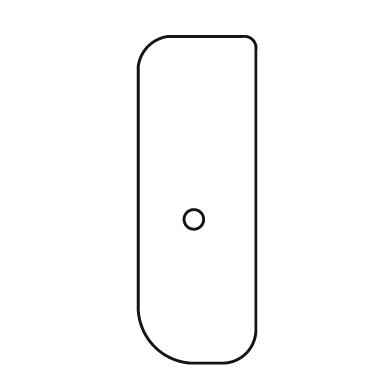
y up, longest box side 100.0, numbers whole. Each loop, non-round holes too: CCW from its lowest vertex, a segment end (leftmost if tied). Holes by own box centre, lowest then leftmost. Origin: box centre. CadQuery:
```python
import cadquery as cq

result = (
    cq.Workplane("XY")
    .moveTo(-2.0, -50.0)
    .lineTo(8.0, -50.0)
    .threePointArc((15.0, -47.0), (18.0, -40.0))
    .lineTo(18.0, 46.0)
    .threePointArc((17.0, 49.0), (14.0, 50.0))
    .lineTo(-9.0, 50.0)
    .threePointArc((-15.0, 47.0), (-18.0, 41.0))
    .lineTo(-18.0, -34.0)
    .threePointArc((-13.0, -45.0), (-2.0, -50.0))
    .close()
    .moveTo(-1.0, -6.0)
    .circle(3.0)
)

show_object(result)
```